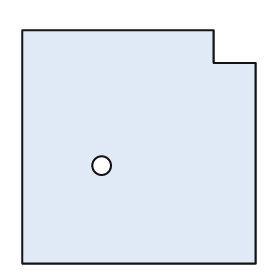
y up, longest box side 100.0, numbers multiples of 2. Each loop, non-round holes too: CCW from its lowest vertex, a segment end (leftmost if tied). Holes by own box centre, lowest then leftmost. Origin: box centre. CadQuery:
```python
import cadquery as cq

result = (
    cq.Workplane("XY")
    .moveTo(-50.0, -50.0)
    .lineTo(50.0, -50.0)
    .lineTo(50.0, 36.0)
    .lineTo(32.0, 36.0)
    .lineTo(32.0, 50.0)
    .lineTo(-50.0, 50.0)
    .close()
    .moveTo(-16.0, -8.0)
    .circle(4.0)
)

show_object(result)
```